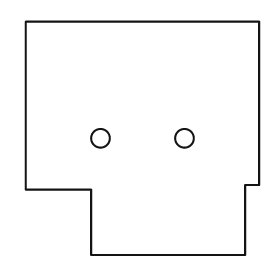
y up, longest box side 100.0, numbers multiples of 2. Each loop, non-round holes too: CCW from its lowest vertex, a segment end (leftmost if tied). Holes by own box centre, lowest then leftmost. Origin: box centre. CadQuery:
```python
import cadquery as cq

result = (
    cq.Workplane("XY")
    .moveTo(-22.0, -50.0)
    .lineTo(44.0, -50.0)
    .lineTo(44.0, -20.0)
    .lineTo(50.0, -20.0)
    .lineTo(50.0, 50.0)
    .lineTo(-50.0, 50.0)
    .lineTo(-50.0, -22.0)
    .lineTo(-22.0, -22.0)
    .close()
    .moveTo(-18.0, 0.0)
    .circle(4.0)
    .moveTo(18.0, 0.0)
    .circle(4.0)
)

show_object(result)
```